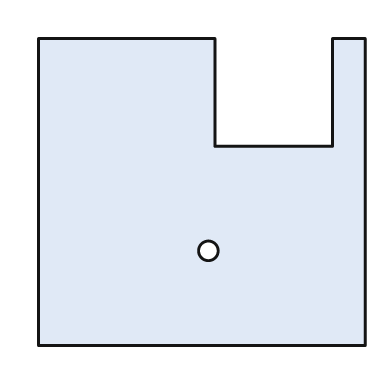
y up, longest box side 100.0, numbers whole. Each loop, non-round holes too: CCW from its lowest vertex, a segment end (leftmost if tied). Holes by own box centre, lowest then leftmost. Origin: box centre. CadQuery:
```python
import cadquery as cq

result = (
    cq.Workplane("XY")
    .moveTo(-50.0, -47.0)
    .lineTo(50.0, -47.0)
    .lineTo(50.0, 47.0)
    .lineTo(40.0, 47.0)
    .lineTo(40.0, 14.0)
    .lineTo(4.0, 14.0)
    .lineTo(4.0, 47.0)
    .lineTo(-50.0, 47.0)
    .close()
    .moveTo(2.0, -18.0)
    .circle(3.0)
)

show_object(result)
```